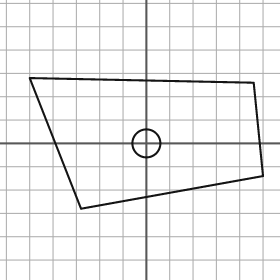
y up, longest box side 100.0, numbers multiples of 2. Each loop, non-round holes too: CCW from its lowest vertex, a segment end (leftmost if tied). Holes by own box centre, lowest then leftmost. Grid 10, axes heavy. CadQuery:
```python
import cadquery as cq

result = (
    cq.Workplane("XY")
    .moveTo(-28.0, -28.0)
    .lineTo(50.0, -14.0)
    .lineTo(46.0, 26.0)
    .lineTo(-50.0, 28.0)
    .close()
    .moveTo(0.0, 0.0)
    .circle(6.0)
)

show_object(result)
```